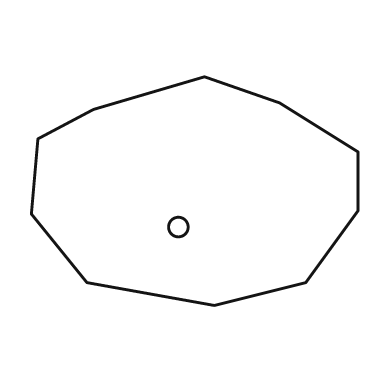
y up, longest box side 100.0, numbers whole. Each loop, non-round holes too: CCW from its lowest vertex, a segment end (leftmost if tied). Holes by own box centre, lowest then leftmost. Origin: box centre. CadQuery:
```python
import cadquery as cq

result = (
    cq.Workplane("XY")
    .moveTo(6.0, -35.0)
    .lineTo(34.0, -28.0)
    .lineTo(50.0, -6.0)
    .lineTo(50.0, 12.0)
    .lineTo(26.0, 27.0)
    .lineTo(3.0, 35.0)
    .lineTo(-31.0, 25.0)
    .lineTo(-48.0, 16.0)
    .lineTo(-50.0, -7.0)
    .lineTo(-33.0, -28.0)
    .close()
    .moveTo(-5.0, -11.0)
    .circle(3.0)
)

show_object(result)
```